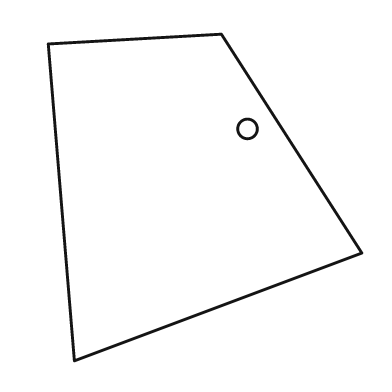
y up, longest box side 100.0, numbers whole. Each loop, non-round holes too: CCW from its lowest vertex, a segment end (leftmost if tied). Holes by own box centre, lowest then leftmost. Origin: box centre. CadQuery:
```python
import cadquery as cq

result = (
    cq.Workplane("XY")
    .moveTo(-40.0, -50.0)
    .lineTo(48.0, -17.0)
    .lineTo(5.0, 50.0)
    .lineTo(-48.0, 47.0)
    .close()
    .moveTo(13.0, 21.0)
    .circle(3.0)
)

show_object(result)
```